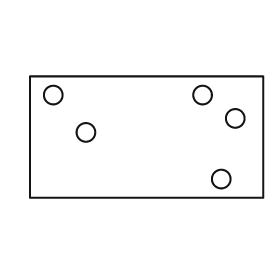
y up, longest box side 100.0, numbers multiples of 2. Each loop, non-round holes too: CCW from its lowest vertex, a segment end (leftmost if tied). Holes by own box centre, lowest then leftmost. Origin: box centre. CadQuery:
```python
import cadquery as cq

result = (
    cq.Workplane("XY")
    .moveTo(-50.0, -26.0)
    .lineTo(50.0, -26.0)
    .lineTo(50.0, 26.0)
    .lineTo(-50.0, 26.0)
    .close()
    .moveTo(32.0, -18.0)
    .circle(4.0)
    .moveTo(-26.0, 2.0)
    .circle(4.0)
    .moveTo(38.0, 8.0)
    .circle(4.0)
    .moveTo(-40.0, 18.0)
    .circle(4.0)
    .moveTo(24.0, 18.0)
    .circle(4.0)
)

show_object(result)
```